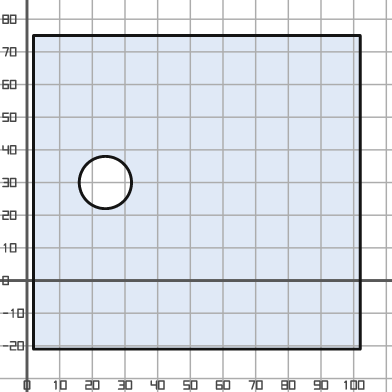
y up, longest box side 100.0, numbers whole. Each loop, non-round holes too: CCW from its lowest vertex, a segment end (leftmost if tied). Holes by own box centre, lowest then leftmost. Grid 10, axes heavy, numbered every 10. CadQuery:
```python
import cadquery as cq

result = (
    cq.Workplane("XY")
    .moveTo(2.0, -21.0)
    .lineTo(102.0, -21.0)
    .lineTo(102.0, 75.0)
    .lineTo(2.0, 75.0)
    .close()
    .moveTo(24.0, 30.0)
    .circle(8.0)
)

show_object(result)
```